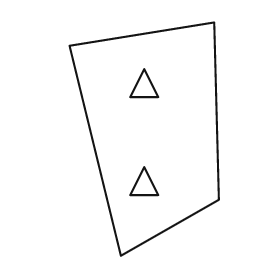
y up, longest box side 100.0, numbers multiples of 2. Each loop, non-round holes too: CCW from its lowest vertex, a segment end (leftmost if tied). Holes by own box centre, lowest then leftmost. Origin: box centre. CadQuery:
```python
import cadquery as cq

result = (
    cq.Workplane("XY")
    .moveTo(-10.0, -50.0)
    .lineTo(32.0, -26.0)
    .lineTo(30.0, 50.0)
    .lineTo(-32.0, 40.0)
    .close()
    .moveTo(-6.0, -24.0)
    .lineTo(6.0, -24.0)
    .lineTo(0.0, -12.0)
    .close()
    .moveTo(-6.0, 18.0)
    .lineTo(6.0, 18.0)
    .lineTo(0.0, 30.0)
    .close()
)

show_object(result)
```